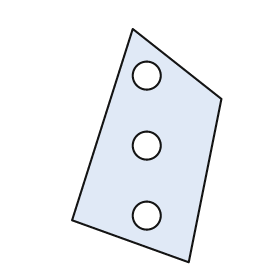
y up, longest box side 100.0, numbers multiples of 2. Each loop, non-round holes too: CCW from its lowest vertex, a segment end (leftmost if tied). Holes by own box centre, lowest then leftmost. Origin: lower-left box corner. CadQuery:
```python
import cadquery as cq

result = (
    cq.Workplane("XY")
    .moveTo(50.0, 0.0)
    .lineTo(64.0, 70.0)
    .lineTo(26.0, 100.0)
    .lineTo(0.0, 18.0)
    .close()
    .moveTo(32.0, 20.0)
    .circle(6.0)
    .moveTo(32.0, 50.0)
    .circle(6.0)
    .moveTo(32.0, 80.0)
    .circle(6.0)
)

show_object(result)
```